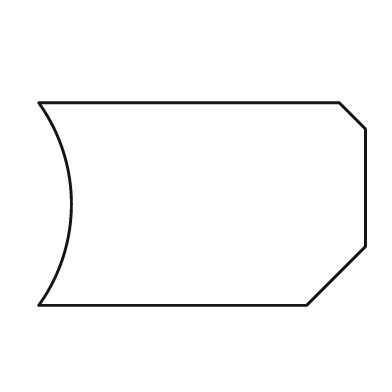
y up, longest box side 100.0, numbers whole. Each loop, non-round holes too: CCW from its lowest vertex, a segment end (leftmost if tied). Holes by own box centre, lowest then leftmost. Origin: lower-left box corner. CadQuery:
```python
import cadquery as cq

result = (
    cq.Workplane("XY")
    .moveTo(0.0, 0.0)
    .lineTo(82.0, 0.0)
    .lineTo(100.0, 18.0)
    .lineTo(100.0, 54.0)
    .lineTo(92.0, 62.0)
    .lineTo(0.0, 62.0)
    .threePointArc((10.0, 31.0), (0.0, 0.0))
    .close()
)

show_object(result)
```